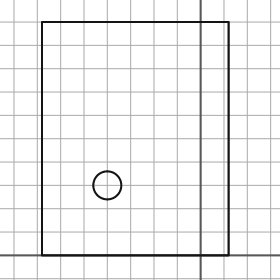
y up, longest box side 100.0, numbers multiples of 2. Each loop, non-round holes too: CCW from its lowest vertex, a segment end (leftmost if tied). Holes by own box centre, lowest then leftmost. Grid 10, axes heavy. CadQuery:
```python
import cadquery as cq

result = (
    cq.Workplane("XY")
    .moveTo(-68.0, 0.0)
    .lineTo(12.0, 0.0)
    .lineTo(12.0, 100.0)
    .lineTo(-68.0, 100.0)
    .close()
    .moveTo(-40.0, 30.0)
    .circle(6.0)
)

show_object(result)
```